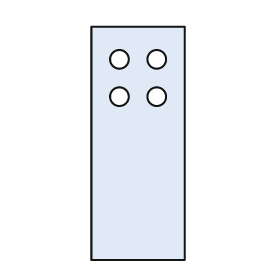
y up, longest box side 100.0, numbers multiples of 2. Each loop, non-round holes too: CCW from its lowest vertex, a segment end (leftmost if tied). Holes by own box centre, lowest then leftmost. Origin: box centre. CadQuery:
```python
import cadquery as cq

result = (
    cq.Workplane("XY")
    .moveTo(-20.0, -50.0)
    .lineTo(20.0, -50.0)
    .lineTo(20.0, 50.0)
    .lineTo(-20.0, 50.0)
    .close()
    .moveTo(-8.0, 20.0)
    .circle(4.0)
    .moveTo(8.0, 20.0)
    .circle(4.0)
    .moveTo(-8.0, 36.0)
    .circle(4.0)
    .moveTo(8.0, 36.0)
    .circle(4.0)
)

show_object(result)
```